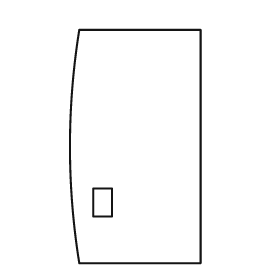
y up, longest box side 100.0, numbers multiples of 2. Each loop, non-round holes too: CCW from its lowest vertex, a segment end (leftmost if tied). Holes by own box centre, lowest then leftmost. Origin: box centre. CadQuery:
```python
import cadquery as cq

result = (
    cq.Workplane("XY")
    .moveTo(-24.0, -50.0)
    .lineTo(28.0, -50.0)
    .lineTo(28.0, 50.0)
    .lineTo(-24.0, 50.0)
    .threePointArc((-28.0, 0.0), (-24.0, -50.0))
    .close()
    .moveTo(-18.0, -30.0)
    .lineTo(-10.0, -30.0)
    .lineTo(-10.0, -18.0)
    .lineTo(-18.0, -18.0)
    .close()
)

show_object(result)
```